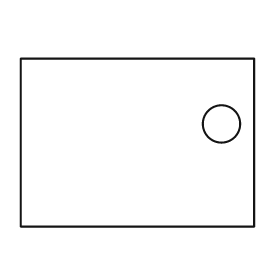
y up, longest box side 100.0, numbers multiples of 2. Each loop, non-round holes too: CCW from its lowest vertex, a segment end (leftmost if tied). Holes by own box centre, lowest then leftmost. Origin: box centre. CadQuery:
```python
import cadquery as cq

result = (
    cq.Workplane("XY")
    .moveTo(-50.0, -36.0)
    .lineTo(50.0, -36.0)
    .lineTo(50.0, 36.0)
    .lineTo(-50.0, 36.0)
    .close()
    .moveTo(36.0, 8.0)
    .circle(8.0)
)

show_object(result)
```